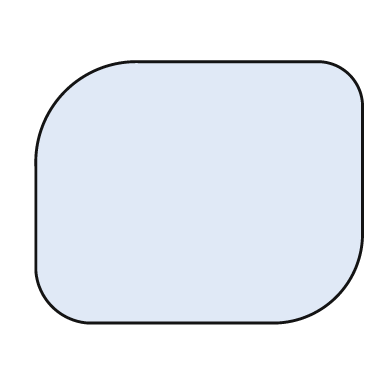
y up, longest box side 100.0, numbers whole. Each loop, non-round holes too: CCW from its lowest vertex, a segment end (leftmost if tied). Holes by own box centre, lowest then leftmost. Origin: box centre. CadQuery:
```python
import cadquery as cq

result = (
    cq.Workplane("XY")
    .moveTo(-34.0, -40.0)
    .lineTo(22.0, -40.0)
    .threePointArc((42.0, -32.0), (50.0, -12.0))
    .lineTo(50.0, 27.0)
    .threePointArc((46.0, 36.0), (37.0, 40.0))
    .lineTo(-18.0, 40.0)
    .threePointArc((-41.0, 31.0), (-50.0, 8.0))
    .lineTo(-50.0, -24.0)
    .threePointArc((-45.0, -35.0), (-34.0, -40.0))
    .close()
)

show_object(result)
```